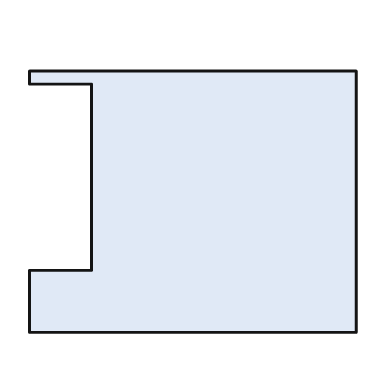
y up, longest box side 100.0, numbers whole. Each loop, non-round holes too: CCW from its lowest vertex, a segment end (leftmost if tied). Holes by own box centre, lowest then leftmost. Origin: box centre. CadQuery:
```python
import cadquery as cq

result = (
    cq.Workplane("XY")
    .moveTo(-50.0, -40.0)
    .lineTo(50.0, -40.0)
    .lineTo(50.0, 40.0)
    .lineTo(-50.0, 40.0)
    .lineTo(-50.0, 36.0)
    .lineTo(-31.0, 36.0)
    .lineTo(-31.0, -21.0)
    .lineTo(-50.0, -21.0)
    .close()
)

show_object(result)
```